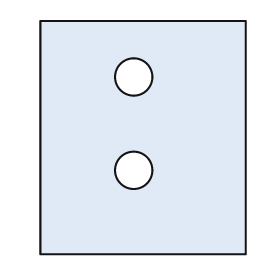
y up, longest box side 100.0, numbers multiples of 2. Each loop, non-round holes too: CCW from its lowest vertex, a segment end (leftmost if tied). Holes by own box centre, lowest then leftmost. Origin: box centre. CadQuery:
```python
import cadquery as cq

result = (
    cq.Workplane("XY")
    .moveTo(-44.0, -50.0)
    .lineTo(44.0, -50.0)
    .lineTo(44.0, 50.0)
    .lineTo(-44.0, 50.0)
    .close()
    .moveTo(-4.0, -14.0)
    .circle(8.0)
    .moveTo(-4.0, 26.0)
    .circle(8.0)
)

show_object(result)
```